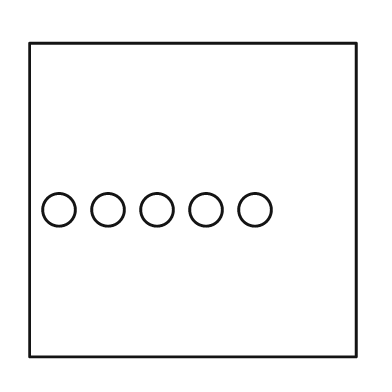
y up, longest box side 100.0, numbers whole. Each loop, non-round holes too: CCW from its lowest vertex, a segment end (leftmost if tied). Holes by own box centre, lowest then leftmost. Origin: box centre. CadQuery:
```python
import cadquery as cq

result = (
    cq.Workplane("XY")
    .moveTo(-50.0, -48.0)
    .lineTo(50.0, -48.0)
    .lineTo(50.0, 48.0)
    .lineTo(-50.0, 48.0)
    .close()
    .moveTo(-41.0, -3.0)
    .circle(5.0)
    .moveTo(-26.0, -3.0)
    .circle(5.0)
    .moveTo(-11.0, -3.0)
    .circle(5.0)
    .moveTo(4.0, -3.0)
    .circle(5.0)
    .moveTo(19.0, -3.0)
    .circle(5.0)
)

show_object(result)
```